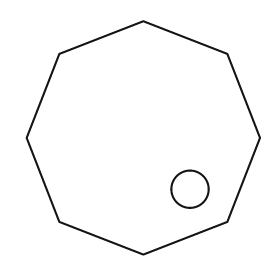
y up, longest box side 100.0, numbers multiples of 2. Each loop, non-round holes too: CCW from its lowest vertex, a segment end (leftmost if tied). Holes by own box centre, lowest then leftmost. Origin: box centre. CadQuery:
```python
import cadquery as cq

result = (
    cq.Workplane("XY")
    .moveTo(0.0, -50.0)
    .lineTo(36.0, -36.0)
    .lineTo(50.0, 0.0)
    .lineTo(36.0, 36.0)
    .lineTo(0.0, 50.0)
    .lineTo(-36.0, 36.0)
    .lineTo(-50.0, 0.0)
    .lineTo(-36.0, -36.0)
    .close()
    .moveTo(20.0, -22.0)
    .circle(8.0)
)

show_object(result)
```